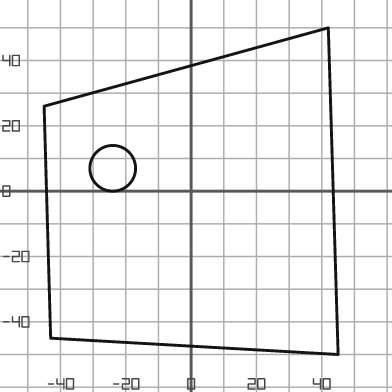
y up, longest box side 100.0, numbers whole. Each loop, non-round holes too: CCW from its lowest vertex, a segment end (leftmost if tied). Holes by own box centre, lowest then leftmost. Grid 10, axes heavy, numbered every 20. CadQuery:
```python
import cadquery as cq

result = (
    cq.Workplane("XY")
    .moveTo(45.0, -50.0)
    .lineTo(42.0, 50.0)
    .lineTo(-45.0, 26.0)
    .lineTo(-43.0, -45.0)
    .close()
    .moveTo(-24.0, 7.0)
    .circle(7.0)
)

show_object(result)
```